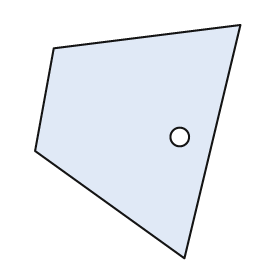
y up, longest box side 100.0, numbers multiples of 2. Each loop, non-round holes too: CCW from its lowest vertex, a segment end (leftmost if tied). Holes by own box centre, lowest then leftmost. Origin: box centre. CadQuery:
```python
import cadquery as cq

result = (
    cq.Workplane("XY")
    .moveTo(20.0, -50.0)
    .lineTo(44.0, 50.0)
    .lineTo(-36.0, 40.0)
    .lineTo(-44.0, -4.0)
    .close()
    .moveTo(18.0, 2.0)
    .circle(4.0)
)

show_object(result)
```